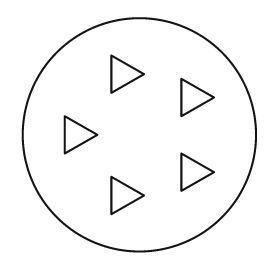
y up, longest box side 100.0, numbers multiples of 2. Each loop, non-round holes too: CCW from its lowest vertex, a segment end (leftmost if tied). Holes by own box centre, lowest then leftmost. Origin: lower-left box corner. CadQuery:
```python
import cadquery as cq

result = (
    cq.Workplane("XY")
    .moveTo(50.0, 50.0)
    .circle(50.0)
    .moveTo(38.0, 16.0)
    .lineTo(52.0, 24.0)
    .lineTo(38.0, 32.0)
    .close()
    .moveTo(68.0, 26.0)
    .lineTo(82.0, 34.0)
    .lineTo(68.0, 42.0)
    .close()
    .moveTo(18.0, 42.0)
    .lineTo(32.0, 50.0)
    .lineTo(18.0, 58.0)
    .close()
    .moveTo(68.0, 58.0)
    .lineTo(82.0, 66.0)
    .lineTo(68.0, 74.0)
    .close()
    .moveTo(38.0, 68.0)
    .lineTo(52.0, 76.0)
    .lineTo(38.0, 84.0)
    .close()
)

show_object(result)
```